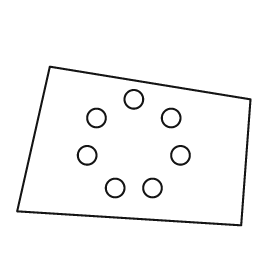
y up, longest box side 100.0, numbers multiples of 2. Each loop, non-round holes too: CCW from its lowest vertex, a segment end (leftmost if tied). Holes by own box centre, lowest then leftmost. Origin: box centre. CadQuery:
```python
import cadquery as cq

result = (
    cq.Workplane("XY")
    .moveTo(46.0, -34.0)
    .lineTo(50.0, 20.0)
    .lineTo(-36.0, 34.0)
    .lineTo(-50.0, -28.0)
    .close()
    .moveTo(-8.0, -18.0)
    .circle(4.0)
    .moveTo(8.0, -18.0)
    .circle(4.0)
    .moveTo(-20.0, -4.0)
    .circle(4.0)
    .moveTo(20.0, -4.0)
    .circle(4.0)
    .moveTo(-16.0, 12.0)
    .circle(4.0)
    .moveTo(16.0, 12.0)
    .circle(4.0)
    .moveTo(0.0, 20.0)
    .circle(4.0)
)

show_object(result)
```